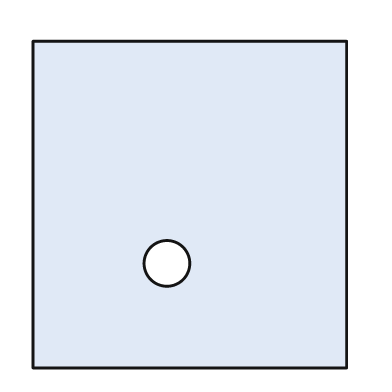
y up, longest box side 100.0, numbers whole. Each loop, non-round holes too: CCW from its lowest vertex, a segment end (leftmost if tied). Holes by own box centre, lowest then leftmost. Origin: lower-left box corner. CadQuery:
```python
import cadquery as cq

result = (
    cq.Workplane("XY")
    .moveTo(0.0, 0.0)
    .lineTo(96.0, 0.0)
    .lineTo(96.0, 100.0)
    .lineTo(0.0, 100.0)
    .close()
    .moveTo(41.0, 32.0)
    .circle(7.0)
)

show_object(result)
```